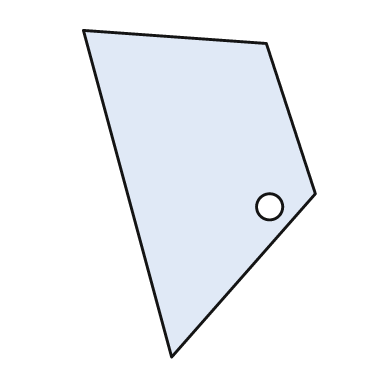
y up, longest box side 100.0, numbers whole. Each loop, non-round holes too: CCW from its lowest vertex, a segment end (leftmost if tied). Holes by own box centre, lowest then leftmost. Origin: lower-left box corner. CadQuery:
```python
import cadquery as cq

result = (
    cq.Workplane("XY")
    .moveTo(27.0, 0.0)
    .lineTo(71.0, 50.0)
    .lineTo(56.0, 96.0)
    .lineTo(0.0, 100.0)
    .close()
    .moveTo(57.0, 46.0)
    .circle(4.0)
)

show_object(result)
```